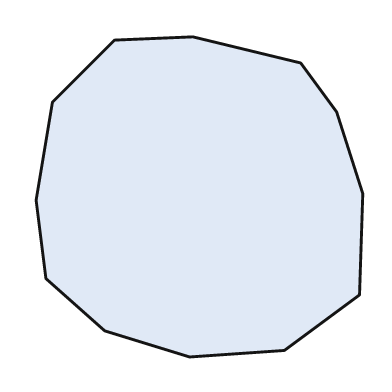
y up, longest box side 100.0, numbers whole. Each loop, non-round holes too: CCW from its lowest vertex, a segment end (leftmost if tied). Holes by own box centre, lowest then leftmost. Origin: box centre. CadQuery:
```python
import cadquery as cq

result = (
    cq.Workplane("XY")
    .moveTo(-3.0, -49.0)
    .lineTo(26.0, -47.0)
    .lineTo(49.0, -30.0)
    .lineTo(50.0, 1.0)
    .lineTo(42.0, 26.0)
    .lineTo(31.0, 41.0)
    .lineTo(-2.0, 49.0)
    .lineTo(-26.0, 48.0)
    .lineTo(-45.0, 29.0)
    .lineTo(-50.0, -1.0)
    .lineTo(-47.0, -25.0)
    .lineTo(-29.0, -41.0)
    .close()
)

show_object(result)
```